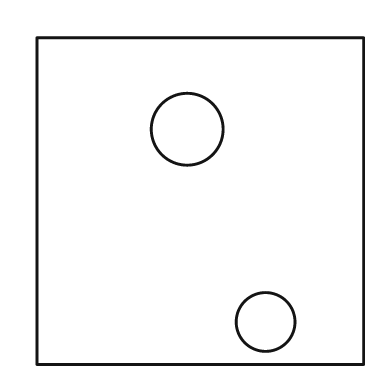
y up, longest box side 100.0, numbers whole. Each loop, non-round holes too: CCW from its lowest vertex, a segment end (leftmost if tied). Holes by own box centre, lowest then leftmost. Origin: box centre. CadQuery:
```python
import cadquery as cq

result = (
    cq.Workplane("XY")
    .moveTo(-50.0, -50.0)
    .lineTo(50.0, -50.0)
    .lineTo(50.0, 50.0)
    .lineTo(-50.0, 50.0)
    .close()
    .moveTo(20.0, -37.0)
    .circle(9.0)
    .moveTo(-4.0, 22.0)
    .circle(11.0)
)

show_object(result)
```